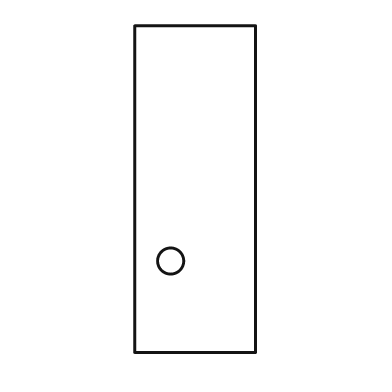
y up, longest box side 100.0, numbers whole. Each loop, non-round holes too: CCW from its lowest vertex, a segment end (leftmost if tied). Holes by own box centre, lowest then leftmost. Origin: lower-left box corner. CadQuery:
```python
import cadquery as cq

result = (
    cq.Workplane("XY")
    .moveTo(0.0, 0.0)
    .lineTo(37.0, 0.0)
    .lineTo(37.0, 100.0)
    .lineTo(0.0, 100.0)
    .close()
    .moveTo(11.0, 28.0)
    .circle(4.0)
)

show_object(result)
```